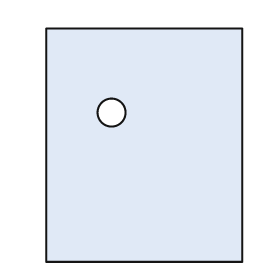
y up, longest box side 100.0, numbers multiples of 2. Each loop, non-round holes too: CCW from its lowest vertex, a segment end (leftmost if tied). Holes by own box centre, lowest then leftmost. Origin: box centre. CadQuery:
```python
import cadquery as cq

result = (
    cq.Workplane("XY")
    .moveTo(-42.0, -50.0)
    .lineTo(42.0, -50.0)
    .lineTo(42.0, 50.0)
    .lineTo(-42.0, 50.0)
    .close()
    .moveTo(-14.0, 14.0)
    .circle(6.0)
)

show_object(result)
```